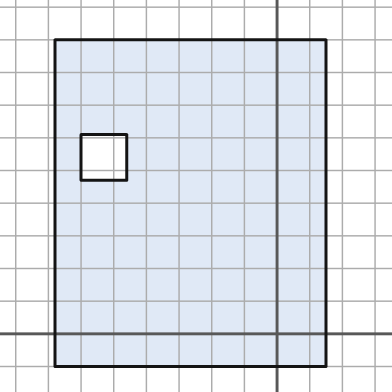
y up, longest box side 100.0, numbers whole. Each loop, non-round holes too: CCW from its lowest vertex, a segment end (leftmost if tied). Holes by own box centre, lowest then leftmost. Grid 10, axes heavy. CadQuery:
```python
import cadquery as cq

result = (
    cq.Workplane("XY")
    .moveTo(-68.0, -10.0)
    .lineTo(15.0, -10.0)
    .lineTo(15.0, 90.0)
    .lineTo(-68.0, 90.0)
    .close()
    .moveTo(-60.0, 47.0)
    .lineTo(-46.0, 47.0)
    .lineTo(-46.0, 61.0)
    .lineTo(-60.0, 61.0)
    .close()
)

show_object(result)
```